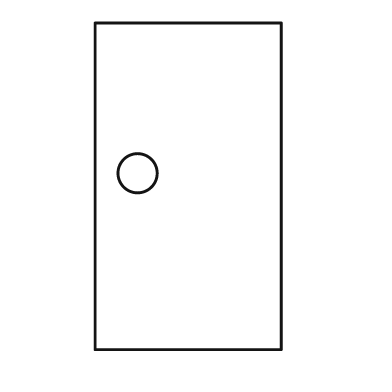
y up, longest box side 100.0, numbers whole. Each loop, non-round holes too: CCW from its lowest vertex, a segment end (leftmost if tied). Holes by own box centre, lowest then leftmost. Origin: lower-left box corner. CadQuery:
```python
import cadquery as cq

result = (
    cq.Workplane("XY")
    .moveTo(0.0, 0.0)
    .lineTo(57.0, 0.0)
    .lineTo(57.0, 100.0)
    .lineTo(0.0, 100.0)
    .close()
    .moveTo(13.0, 54.0)
    .circle(6.0)
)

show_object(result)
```